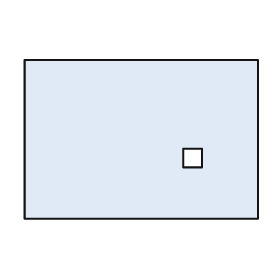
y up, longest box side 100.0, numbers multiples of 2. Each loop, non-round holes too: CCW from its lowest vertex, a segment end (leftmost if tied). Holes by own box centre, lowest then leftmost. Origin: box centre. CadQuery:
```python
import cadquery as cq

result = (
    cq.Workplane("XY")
    .moveTo(-50.0, -34.0)
    .lineTo(50.0, -34.0)
    .lineTo(50.0, 34.0)
    .lineTo(-50.0, 34.0)
    .close()
    .moveTo(18.0, -12.0)
    .lineTo(26.0, -12.0)
    .lineTo(26.0, -4.0)
    .lineTo(18.0, -4.0)
    .close()
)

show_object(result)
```